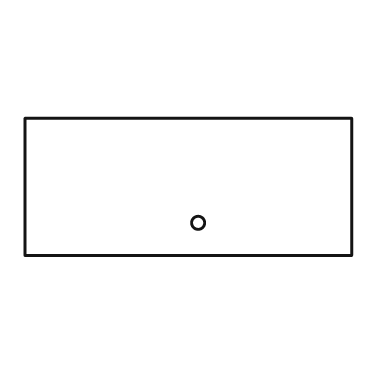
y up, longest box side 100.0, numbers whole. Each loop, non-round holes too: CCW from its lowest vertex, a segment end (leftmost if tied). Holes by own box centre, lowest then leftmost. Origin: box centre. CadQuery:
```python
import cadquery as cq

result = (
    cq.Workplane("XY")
    .moveTo(-50.0, -21.0)
    .lineTo(50.0, -21.0)
    .lineTo(50.0, 21.0)
    .lineTo(-50.0, 21.0)
    .close()
    .moveTo(3.0, -11.0)
    .circle(2.0)
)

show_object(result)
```